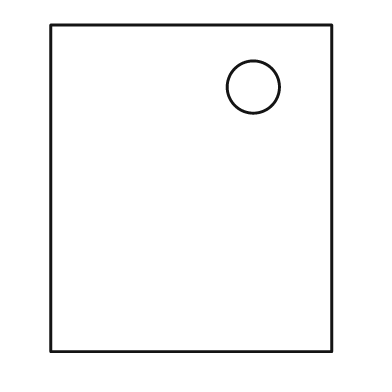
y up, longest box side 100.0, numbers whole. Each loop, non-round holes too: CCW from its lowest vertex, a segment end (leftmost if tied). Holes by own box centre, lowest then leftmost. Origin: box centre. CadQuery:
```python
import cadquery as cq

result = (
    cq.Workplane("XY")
    .moveTo(-43.0, -50.0)
    .lineTo(43.0, -50.0)
    .lineTo(43.0, 50.0)
    .lineTo(-43.0, 50.0)
    .close()
    .moveTo(19.0, 31.0)
    .circle(8.0)
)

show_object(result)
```